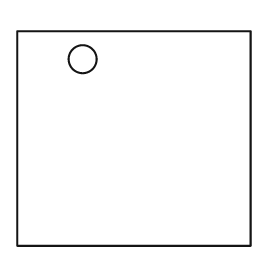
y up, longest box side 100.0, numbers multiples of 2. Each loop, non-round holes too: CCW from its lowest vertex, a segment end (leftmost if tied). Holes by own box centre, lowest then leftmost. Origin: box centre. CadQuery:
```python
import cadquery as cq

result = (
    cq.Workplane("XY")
    .moveTo(-50.0, -46.0)
    .lineTo(50.0, -46.0)
    .lineTo(50.0, 46.0)
    .lineTo(-50.0, 46.0)
    .close()
    .moveTo(-22.0, 34.0)
    .circle(6.0)
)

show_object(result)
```